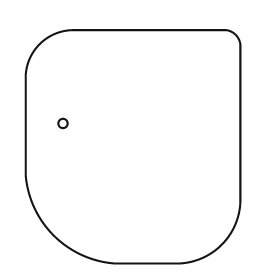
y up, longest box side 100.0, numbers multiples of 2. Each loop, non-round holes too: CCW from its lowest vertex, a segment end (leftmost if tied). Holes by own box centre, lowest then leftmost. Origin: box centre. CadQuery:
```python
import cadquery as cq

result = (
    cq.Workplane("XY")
    .moveTo(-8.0, -50.0)
    .lineTo(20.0, -50.0)
    .threePointArc((38.0, -42.0), (46.0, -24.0))
    .lineTo(46.0, 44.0)
    .threePointArc((44.0, 48.0), (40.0, 50.0))
    .lineTo(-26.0, 50.0)
    .threePointArc((-40.0, 44.0), (-46.0, 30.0))
    .lineTo(-46.0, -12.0)
    .threePointArc((-34.0, -38.0), (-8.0, -50.0))
    .close()
    .moveTo(-30.0, 10.0)
    .circle(2.0)
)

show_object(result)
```